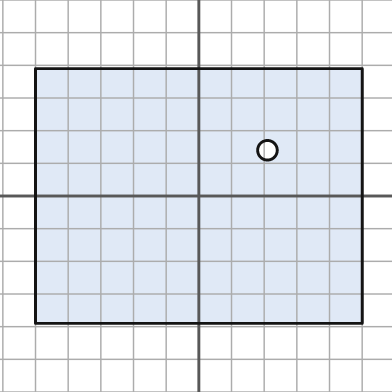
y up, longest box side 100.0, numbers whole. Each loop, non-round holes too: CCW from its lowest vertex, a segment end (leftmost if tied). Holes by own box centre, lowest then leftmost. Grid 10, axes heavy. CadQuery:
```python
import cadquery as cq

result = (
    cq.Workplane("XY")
    .moveTo(-50.0, -39.0)
    .lineTo(50.0, -39.0)
    .lineTo(50.0, 39.0)
    .lineTo(-50.0, 39.0)
    .close()
    .moveTo(21.0, 14.0)
    .circle(3.0)
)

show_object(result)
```